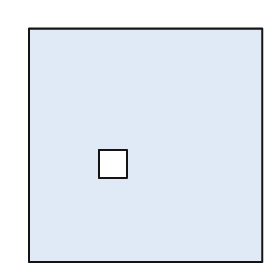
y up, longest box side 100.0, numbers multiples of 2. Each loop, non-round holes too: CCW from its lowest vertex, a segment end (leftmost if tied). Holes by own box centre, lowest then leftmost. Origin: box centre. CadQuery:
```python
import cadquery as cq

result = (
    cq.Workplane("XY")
    .moveTo(-50.0, -50.0)
    .lineTo(50.0, -50.0)
    .lineTo(50.0, 50.0)
    .lineTo(-50.0, 50.0)
    .close()
    .moveTo(-20.0, -14.0)
    .lineTo(-8.0, -14.0)
    .lineTo(-8.0, -2.0)
    .lineTo(-20.0, -2.0)
    .close()
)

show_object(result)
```